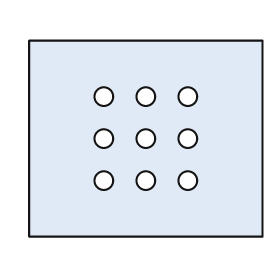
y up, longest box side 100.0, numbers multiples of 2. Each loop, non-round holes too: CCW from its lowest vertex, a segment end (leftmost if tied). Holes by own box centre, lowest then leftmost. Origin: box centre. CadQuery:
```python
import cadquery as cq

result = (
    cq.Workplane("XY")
    .moveTo(-50.0, -42.0)
    .lineTo(50.0, -42.0)
    .lineTo(50.0, 42.0)
    .lineTo(-50.0, 42.0)
    .close()
    .moveTo(-18.0, -18.0)
    .circle(4.0)
    .moveTo(0.0, -18.0)
    .circle(4.0)
    .moveTo(18.0, -18.0)
    .circle(4.0)
    .moveTo(-18.0, 0.0)
    .circle(4.0)
    .moveTo(0.0, 0.0)
    .circle(4.0)
    .moveTo(18.0, 0.0)
    .circle(4.0)
    .moveTo(-18.0, 18.0)
    .circle(4.0)
    .moveTo(0.0, 18.0)
    .circle(4.0)
    .moveTo(18.0, 18.0)
    .circle(4.0)
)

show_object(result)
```